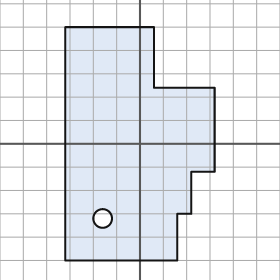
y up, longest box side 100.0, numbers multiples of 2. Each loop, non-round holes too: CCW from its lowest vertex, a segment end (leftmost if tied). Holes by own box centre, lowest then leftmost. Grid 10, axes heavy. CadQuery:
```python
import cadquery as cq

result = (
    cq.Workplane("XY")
    .moveTo(-32.0, -50.0)
    .lineTo(16.0, -50.0)
    .lineTo(16.0, -30.0)
    .lineTo(22.0, -30.0)
    .lineTo(22.0, -12.0)
    .lineTo(32.0, -12.0)
    .lineTo(32.0, 24.0)
    .lineTo(6.0, 24.0)
    .lineTo(6.0, 50.0)
    .lineTo(-32.0, 50.0)
    .close()
    .moveTo(-16.0, -32.0)
    .circle(4.0)
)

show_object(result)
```